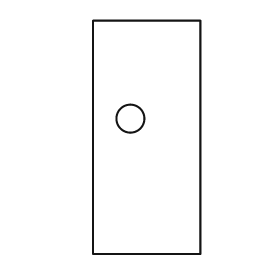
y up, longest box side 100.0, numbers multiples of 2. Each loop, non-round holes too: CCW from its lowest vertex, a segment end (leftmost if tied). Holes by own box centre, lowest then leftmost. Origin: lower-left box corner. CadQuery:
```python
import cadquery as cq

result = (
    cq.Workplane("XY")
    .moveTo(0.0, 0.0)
    .lineTo(46.0, 0.0)
    .lineTo(46.0, 100.0)
    .lineTo(0.0, 100.0)
    .close()
    .moveTo(16.0, 58.0)
    .circle(6.0)
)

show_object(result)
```